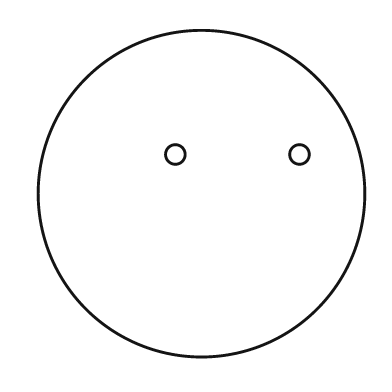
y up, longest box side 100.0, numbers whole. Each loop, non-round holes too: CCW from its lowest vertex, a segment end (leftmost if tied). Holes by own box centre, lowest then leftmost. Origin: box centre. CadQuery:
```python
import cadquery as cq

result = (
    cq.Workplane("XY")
    .moveTo(0.0, 0.0)
    .circle(50.0)
    .moveTo(-8.0, 12.0)
    .circle(3.0)
    .moveTo(30.0, 12.0)
    .circle(3.0)
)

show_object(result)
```